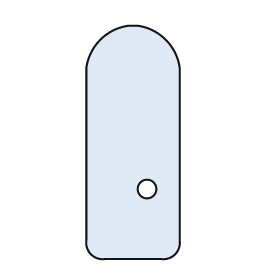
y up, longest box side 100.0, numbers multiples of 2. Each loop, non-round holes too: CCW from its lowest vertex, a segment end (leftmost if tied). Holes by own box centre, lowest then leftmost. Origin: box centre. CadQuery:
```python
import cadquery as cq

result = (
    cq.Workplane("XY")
    .moveTo(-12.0, -50.0)
    .lineTo(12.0, -50.0)
    .threePointArc((18.0, -48.0), (20.0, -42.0))
    .lineTo(20.0, 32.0)
    .threePointArc((14.0, 44.0), (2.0, 50.0))
    .lineTo(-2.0, 50.0)
    .threePointArc((-14.0, 44.0), (-20.0, 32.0))
    .lineTo(-20.0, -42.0)
    .threePointArc((-18.0, -48.0), (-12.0, -50.0))
    .close()
    .moveTo(6.0, -20.0)
    .circle(4.0)
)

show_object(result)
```